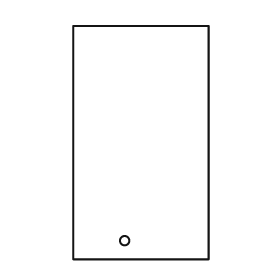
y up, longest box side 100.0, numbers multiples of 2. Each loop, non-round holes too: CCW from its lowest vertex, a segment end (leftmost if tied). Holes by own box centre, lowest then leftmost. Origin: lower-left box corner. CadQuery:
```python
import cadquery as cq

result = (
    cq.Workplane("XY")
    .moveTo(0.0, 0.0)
    .lineTo(58.0, 0.0)
    .lineTo(58.0, 100.0)
    .lineTo(0.0, 100.0)
    .close()
    .moveTo(22.0, 8.0)
    .circle(2.0)
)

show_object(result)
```